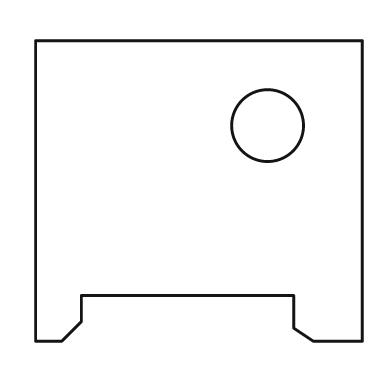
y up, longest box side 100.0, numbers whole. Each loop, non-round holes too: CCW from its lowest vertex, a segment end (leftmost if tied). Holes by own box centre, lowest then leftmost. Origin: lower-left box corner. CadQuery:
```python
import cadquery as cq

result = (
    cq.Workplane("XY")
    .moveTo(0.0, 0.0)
    .lineTo(8.0, 0.0)
    .lineTo(14.0, 6.0)
    .lineTo(14.0, 14.0)
    .lineTo(79.0, 14.0)
    .lineTo(79.0, 4.0)
    .lineTo(85.0, 0.0)
    .lineTo(100.0, 0.0)
    .lineTo(100.0, 92.0)
    .lineTo(0.0, 92.0)
    .close()
    .moveTo(71.0, 66.0)
    .circle(11.0)
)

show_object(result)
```